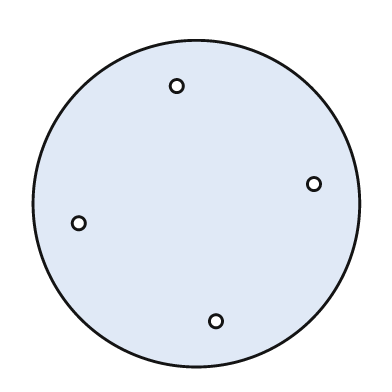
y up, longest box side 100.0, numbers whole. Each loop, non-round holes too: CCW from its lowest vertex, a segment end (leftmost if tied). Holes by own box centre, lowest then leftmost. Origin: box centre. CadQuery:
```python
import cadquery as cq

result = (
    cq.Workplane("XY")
    .moveTo(0.0, 0.0)
    .circle(50.0)
    .moveTo(6.0, -36.0)
    .circle(2.0)
    .moveTo(-36.0, -6.0)
    .circle(2.0)
    .moveTo(36.0, 6.0)
    .circle(2.0)
    .moveTo(-6.0, 36.0)
    .circle(2.0)
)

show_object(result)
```